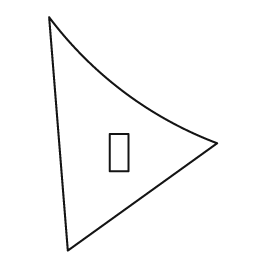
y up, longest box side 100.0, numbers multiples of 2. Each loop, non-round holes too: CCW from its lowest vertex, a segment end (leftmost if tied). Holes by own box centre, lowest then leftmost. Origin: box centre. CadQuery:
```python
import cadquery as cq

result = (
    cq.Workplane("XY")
    .moveTo(-28.0, -50.0)
    .lineTo(36.0, -4.0)
    .threePointArc((-4.0, 18.0), (-36.0, 50.0))
    .close()
    .moveTo(-10.0, -16.0)
    .lineTo(-2.0, -16.0)
    .lineTo(-2.0, 0.0)
    .lineTo(-10.0, 0.0)
    .close()
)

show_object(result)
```